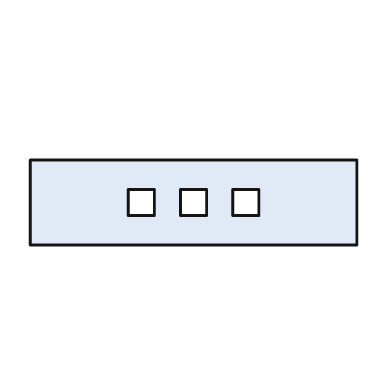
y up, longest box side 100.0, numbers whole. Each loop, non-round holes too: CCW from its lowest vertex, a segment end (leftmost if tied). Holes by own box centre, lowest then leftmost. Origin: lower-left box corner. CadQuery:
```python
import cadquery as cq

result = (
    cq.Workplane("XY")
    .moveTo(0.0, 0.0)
    .lineTo(100.0, 0.0)
    .lineTo(100.0, 26.0)
    .lineTo(0.0, 26.0)
    .close()
    .moveTo(30.0, 9.0)
    .lineTo(38.0, 9.0)
    .lineTo(38.0, 17.0)
    .lineTo(30.0, 17.0)
    .close()
    .moveTo(46.0, 9.0)
    .lineTo(54.0, 9.0)
    .lineTo(54.0, 17.0)
    .lineTo(46.0, 17.0)
    .close()
    .moveTo(62.0, 9.0)
    .lineTo(70.0, 9.0)
    .lineTo(70.0, 17.0)
    .lineTo(62.0, 17.0)
    .close()
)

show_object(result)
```